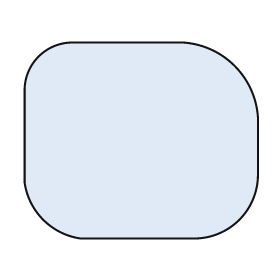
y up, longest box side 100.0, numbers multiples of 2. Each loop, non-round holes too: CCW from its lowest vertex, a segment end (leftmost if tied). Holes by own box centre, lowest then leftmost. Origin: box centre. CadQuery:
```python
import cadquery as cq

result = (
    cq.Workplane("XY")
    .moveTo(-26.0, -42.0)
    .lineTo(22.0, -42.0)
    .threePointArc((42.0, -34.0), (50.0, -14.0))
    .lineTo(50.0, 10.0)
    .threePointArc((40.0, 32.0), (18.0, 42.0))
    .lineTo(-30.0, 42.0)
    .threePointArc((-44.0, 36.0), (-50.0, 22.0))
    .lineTo(-50.0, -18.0)
    .threePointArc((-42.0, -34.0), (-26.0, -42.0))
    .close()
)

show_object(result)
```